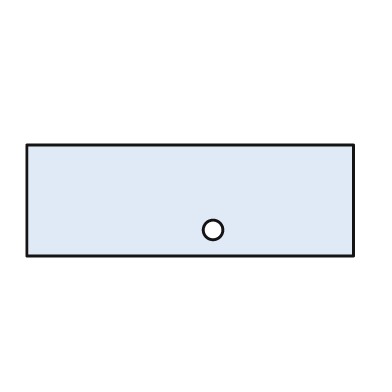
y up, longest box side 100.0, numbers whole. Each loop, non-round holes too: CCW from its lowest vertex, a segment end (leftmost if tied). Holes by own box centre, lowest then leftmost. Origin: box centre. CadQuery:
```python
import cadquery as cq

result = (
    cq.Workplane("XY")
    .moveTo(-50.0, -17.0)
    .lineTo(50.0, -17.0)
    .lineTo(50.0, 17.0)
    .lineTo(-50.0, 17.0)
    .close()
    .moveTo(7.0, -9.0)
    .circle(3.0)
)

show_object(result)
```